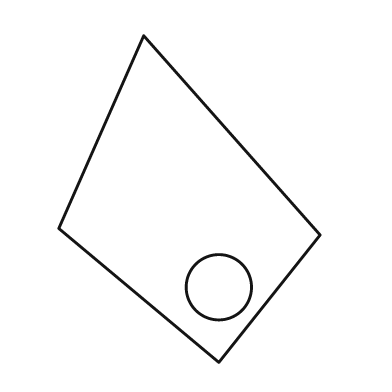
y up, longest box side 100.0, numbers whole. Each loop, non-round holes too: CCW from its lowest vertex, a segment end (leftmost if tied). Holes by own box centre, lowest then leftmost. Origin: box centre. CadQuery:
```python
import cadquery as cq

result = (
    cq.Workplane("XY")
    .moveTo(9.0, -50.0)
    .lineTo(40.0, -11.0)
    .lineTo(-14.0, 50.0)
    .lineTo(-40.0, -9.0)
    .close()
    .moveTo(9.0, -27.0)
    .circle(10.0)
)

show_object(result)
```